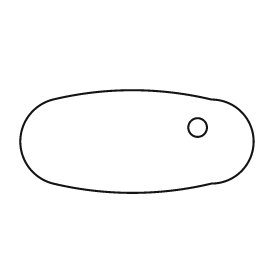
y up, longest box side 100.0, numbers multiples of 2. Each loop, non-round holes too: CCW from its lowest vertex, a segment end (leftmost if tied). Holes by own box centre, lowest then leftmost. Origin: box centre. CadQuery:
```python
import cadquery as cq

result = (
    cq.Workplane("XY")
    .moveTo(-36.0, -18.0)
    .threePointArc((-2.0, -22.0), (32.0, -18.0))
    .threePointArc((50.0, 0.0), (32.0, 18.0))
    .threePointArc((-2.0, 22.0), (-36.0, 18.0))
    .threePointArc((-50.0, 0.0), (-36.0, -18.0))
    .close()
    .moveTo(26.0, 6.0)
    .circle(4.0)
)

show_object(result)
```